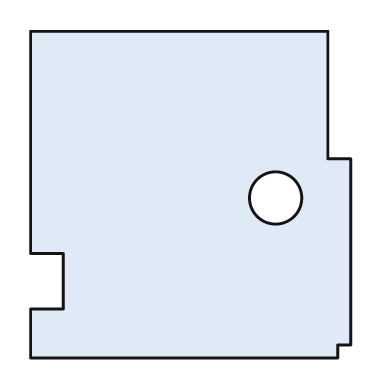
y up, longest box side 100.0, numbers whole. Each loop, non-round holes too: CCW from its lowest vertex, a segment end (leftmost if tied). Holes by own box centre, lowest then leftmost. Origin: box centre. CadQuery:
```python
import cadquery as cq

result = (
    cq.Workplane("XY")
    .moveTo(-49.0, -50.0)
    .lineTo(45.0, -50.0)
    .lineTo(45.0, -46.0)
    .lineTo(49.0, -46.0)
    .lineTo(49.0, 11.0)
    .lineTo(42.0, 11.0)
    .lineTo(42.0, 50.0)
    .lineTo(-49.0, 50.0)
    .lineTo(-49.0, -18.0)
    .lineTo(-39.0, -18.0)
    .lineTo(-39.0, -35.0)
    .lineTo(-49.0, -35.0)
    .close()
    .moveTo(26.0, -1.0)
    .circle(8.0)
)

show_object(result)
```